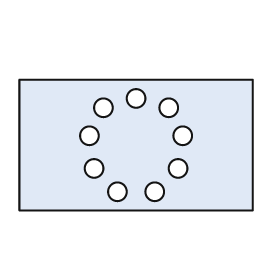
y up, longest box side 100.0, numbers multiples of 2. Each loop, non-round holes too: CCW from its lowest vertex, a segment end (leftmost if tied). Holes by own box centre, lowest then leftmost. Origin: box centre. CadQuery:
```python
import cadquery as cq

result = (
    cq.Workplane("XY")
    .moveTo(-50.0, -28.0)
    .lineTo(50.0, -28.0)
    .lineTo(50.0, 28.0)
    .lineTo(-50.0, 28.0)
    .close()
    .moveTo(-8.0, -20.0)
    .circle(4.0)
    .moveTo(8.0, -20.0)
    .circle(4.0)
    .moveTo(-18.0, -10.0)
    .circle(4.0)
    .moveTo(18.0, -10.0)
    .circle(4.0)
    .moveTo(-20.0, 4.0)
    .circle(4.0)
    .moveTo(20.0, 4.0)
    .circle(4.0)
    .moveTo(-14.0, 16.0)
    .circle(4.0)
    .moveTo(14.0, 16.0)
    .circle(4.0)
    .moveTo(0.0, 20.0)
    .circle(4.0)
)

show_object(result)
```